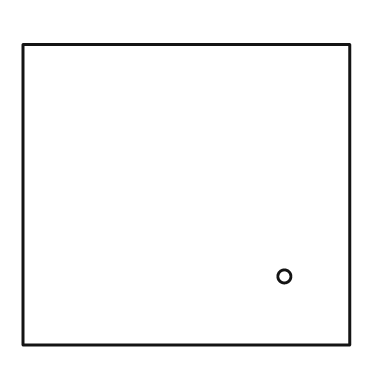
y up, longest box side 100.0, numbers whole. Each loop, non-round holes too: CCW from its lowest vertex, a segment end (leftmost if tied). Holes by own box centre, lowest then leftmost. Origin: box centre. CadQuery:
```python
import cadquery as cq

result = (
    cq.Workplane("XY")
    .moveTo(-50.0, -46.0)
    .lineTo(50.0, -46.0)
    .lineTo(50.0, 46.0)
    .lineTo(-50.0, 46.0)
    .close()
    .moveTo(30.0, -25.0)
    .circle(2.0)
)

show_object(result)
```